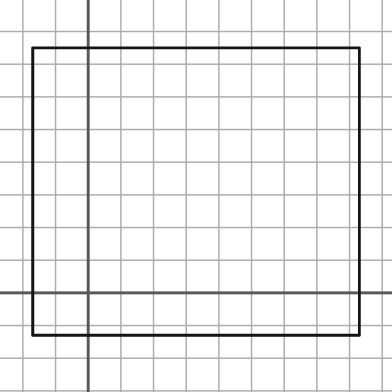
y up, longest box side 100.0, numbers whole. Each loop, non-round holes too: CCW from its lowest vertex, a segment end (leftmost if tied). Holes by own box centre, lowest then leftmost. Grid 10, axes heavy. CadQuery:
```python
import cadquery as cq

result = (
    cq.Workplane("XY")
    .moveTo(-17.0, -13.0)
    .lineTo(83.0, -13.0)
    .lineTo(83.0, 75.0)
    .lineTo(-17.0, 75.0)
    .close()
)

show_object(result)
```